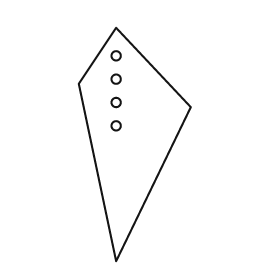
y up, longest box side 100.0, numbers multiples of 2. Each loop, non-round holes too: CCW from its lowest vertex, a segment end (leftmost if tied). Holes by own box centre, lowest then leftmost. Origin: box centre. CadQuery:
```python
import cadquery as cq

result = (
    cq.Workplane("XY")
    .moveTo(-8.0, -50.0)
    .lineTo(24.0, 16.0)
    .lineTo(-8.0, 50.0)
    .lineTo(-24.0, 26.0)
    .close()
    .moveTo(-8.0, 8.0)
    .circle(2.0)
    .moveTo(-8.0, 18.0)
    .circle(2.0)
    .moveTo(-8.0, 28.0)
    .circle(2.0)
    .moveTo(-8.0, 38.0)
    .circle(2.0)
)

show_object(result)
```